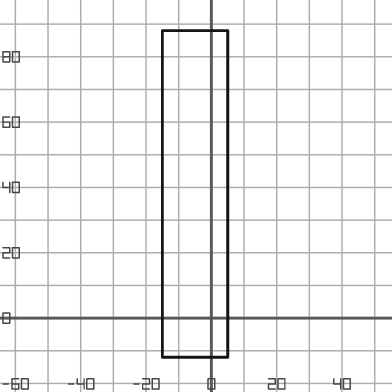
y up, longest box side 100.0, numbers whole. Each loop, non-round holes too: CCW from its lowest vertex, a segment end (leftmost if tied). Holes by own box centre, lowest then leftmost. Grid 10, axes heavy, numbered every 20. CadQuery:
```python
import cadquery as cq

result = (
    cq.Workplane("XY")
    .moveTo(-15.0, -12.0)
    .lineTo(5.0, -12.0)
    .lineTo(5.0, 88.0)
    .lineTo(-15.0, 88.0)
    .close()
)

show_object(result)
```